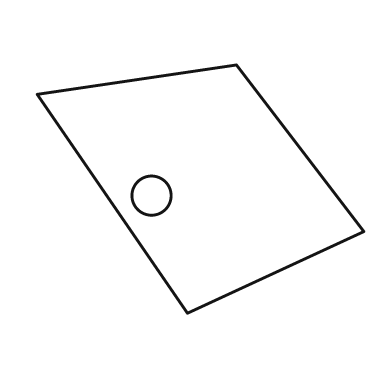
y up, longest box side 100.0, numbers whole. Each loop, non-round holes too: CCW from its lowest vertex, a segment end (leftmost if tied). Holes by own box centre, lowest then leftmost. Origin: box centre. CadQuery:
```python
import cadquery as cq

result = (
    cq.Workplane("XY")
    .moveTo(-4.0, -38.0)
    .lineTo(50.0, -13.0)
    .lineTo(11.0, 38.0)
    .lineTo(-50.0, 29.0)
    .close()
    .moveTo(-15.0, -2.0)
    .circle(6.0)
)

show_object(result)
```